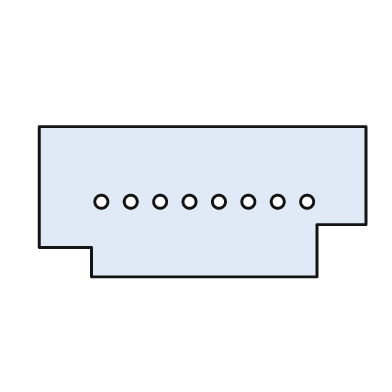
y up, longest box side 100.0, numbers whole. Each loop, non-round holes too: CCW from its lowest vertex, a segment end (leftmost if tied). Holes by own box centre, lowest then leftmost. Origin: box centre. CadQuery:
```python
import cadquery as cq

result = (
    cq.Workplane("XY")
    .moveTo(-34.0, -23.0)
    .lineTo(35.0, -23.0)
    .lineTo(35.0, -7.0)
    .lineTo(50.0, -7.0)
    .lineTo(50.0, 23.0)
    .lineTo(-50.0, 23.0)
    .lineTo(-50.0, -14.0)
    .lineTo(-34.0, -14.0)
    .close()
    .moveTo(-31.0, 0.0)
    .circle(2.0)
    .moveTo(-22.0, 0.0)
    .circle(2.0)
    .moveTo(-13.0, 0.0)
    .circle(2.0)
    .moveTo(-4.0, 0.0)
    .circle(2.0)
    .moveTo(5.0, 0.0)
    .circle(2.0)
    .moveTo(14.0, 0.0)
    .circle(2.0)
    .moveTo(23.0, 0.0)
    .circle(2.0)
    .moveTo(32.0, 0.0)
    .circle(2.0)
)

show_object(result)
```